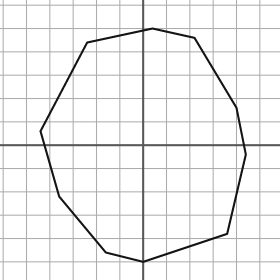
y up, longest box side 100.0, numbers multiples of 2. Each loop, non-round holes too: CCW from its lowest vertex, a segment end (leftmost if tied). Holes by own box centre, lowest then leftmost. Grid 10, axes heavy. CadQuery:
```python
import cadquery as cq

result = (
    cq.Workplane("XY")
    .moveTo(0.0, -50.0)
    .lineTo(36.0, -38.0)
    .lineTo(44.0, -4.0)
    .lineTo(40.0, 16.0)
    .lineTo(22.0, 46.0)
    .lineTo(4.0, 50.0)
    .lineTo(-24.0, 44.0)
    .lineTo(-44.0, 6.0)
    .lineTo(-36.0, -22.0)
    .lineTo(-16.0, -46.0)
    .close()
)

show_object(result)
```